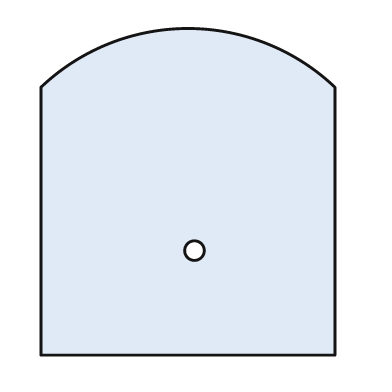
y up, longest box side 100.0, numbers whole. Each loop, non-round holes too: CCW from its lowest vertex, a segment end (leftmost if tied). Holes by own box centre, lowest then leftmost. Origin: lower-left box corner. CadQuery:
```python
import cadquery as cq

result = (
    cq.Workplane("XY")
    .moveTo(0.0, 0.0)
    .lineTo(90.0, 0.0)
    .lineTo(90.0, 82.0)
    .threePointArc((45.0, 100.0), (0.0, 82.0))
    .close()
    .moveTo(47.0, 32.0)
    .circle(3.0)
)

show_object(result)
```